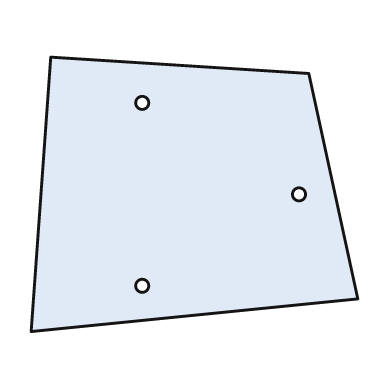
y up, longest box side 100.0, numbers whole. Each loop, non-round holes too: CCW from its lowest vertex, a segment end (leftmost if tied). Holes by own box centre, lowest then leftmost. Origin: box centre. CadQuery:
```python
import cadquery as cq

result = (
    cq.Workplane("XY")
    .moveTo(-50.0, -42.0)
    .lineTo(50.0, -32.0)
    .lineTo(35.0, 37.0)
    .lineTo(-44.0, 42.0)
    .close()
    .moveTo(-16.0, -28.0)
    .circle(2.0)
    .moveTo(32.0, 0.0)
    .circle(2.0)
    .moveTo(-16.0, 28.0)
    .circle(2.0)
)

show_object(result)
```